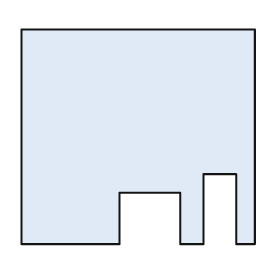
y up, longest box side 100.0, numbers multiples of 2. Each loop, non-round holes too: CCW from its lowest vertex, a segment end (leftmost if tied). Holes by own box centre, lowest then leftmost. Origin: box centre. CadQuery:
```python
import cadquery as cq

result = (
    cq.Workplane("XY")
    .moveTo(-50.0, -46.0)
    .lineTo(-8.0, -46.0)
    .lineTo(-8.0, -24.0)
    .lineTo(18.0, -24.0)
    .lineTo(18.0, -46.0)
    .lineTo(28.0, -46.0)
    .lineTo(28.0, -16.0)
    .lineTo(42.0, -16.0)
    .lineTo(42.0, -46.0)
    .lineTo(50.0, -46.0)
    .lineTo(50.0, 46.0)
    .lineTo(-50.0, 46.0)
    .close()
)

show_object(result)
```